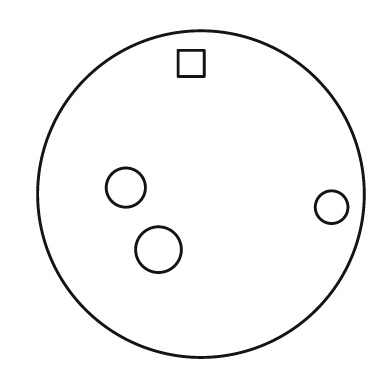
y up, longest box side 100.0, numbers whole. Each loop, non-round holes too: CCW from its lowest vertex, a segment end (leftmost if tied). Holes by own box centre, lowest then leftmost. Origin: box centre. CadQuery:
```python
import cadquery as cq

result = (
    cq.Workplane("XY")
    .moveTo(0.0, 0.0)
    .circle(50.0)
    .moveTo(-13.0, -17.0)
    .circle(7.0)
    .moveTo(40.0, -4.0)
    .circle(5.0)
    .moveTo(-23.0, 2.0)
    .circle(6.0)
    .moveTo(-7.0, 36.0)
    .lineTo(1.0, 36.0)
    .lineTo(1.0, 44.0)
    .lineTo(-7.0, 44.0)
    .close()
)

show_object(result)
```